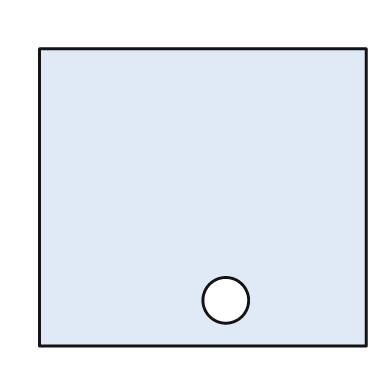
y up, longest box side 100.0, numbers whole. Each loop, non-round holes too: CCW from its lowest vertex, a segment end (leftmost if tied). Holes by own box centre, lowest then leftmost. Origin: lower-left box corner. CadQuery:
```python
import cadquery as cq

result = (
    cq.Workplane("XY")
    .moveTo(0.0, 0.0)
    .lineTo(100.0, 0.0)
    .lineTo(100.0, 91.0)
    .lineTo(0.0, 91.0)
    .close()
    .moveTo(57.0, 14.0)
    .circle(7.0)
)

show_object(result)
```